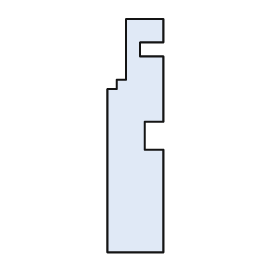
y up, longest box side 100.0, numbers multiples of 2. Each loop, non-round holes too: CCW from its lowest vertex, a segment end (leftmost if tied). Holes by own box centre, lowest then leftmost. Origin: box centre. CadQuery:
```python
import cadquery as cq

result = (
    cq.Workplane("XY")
    .moveTo(-12.0, -50.0)
    .lineTo(12.0, -50.0)
    .lineTo(12.0, -6.0)
    .lineTo(4.0, -6.0)
    .lineTo(4.0, 6.0)
    .lineTo(12.0, 6.0)
    .lineTo(12.0, 34.0)
    .lineTo(2.0, 34.0)
    .lineTo(2.0, 40.0)
    .lineTo(12.0, 40.0)
    .lineTo(12.0, 50.0)
    .lineTo(-4.0, 50.0)
    .lineTo(-4.0, 24.0)
    .lineTo(-8.0, 24.0)
    .lineTo(-8.0, 20.0)
    .lineTo(-12.0, 20.0)
    .close()
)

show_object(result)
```